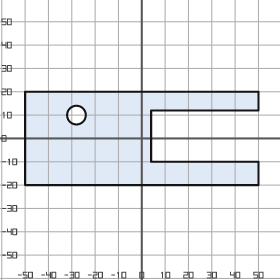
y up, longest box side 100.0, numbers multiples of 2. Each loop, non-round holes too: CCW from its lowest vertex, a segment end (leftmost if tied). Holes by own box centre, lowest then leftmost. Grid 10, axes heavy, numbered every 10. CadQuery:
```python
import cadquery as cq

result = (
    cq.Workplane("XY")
    .moveTo(-50.0, -20.0)
    .lineTo(50.0, -20.0)
    .lineTo(50.0, -10.0)
    .lineTo(4.0, -10.0)
    .lineTo(4.0, 12.0)
    .lineTo(50.0, 12.0)
    .lineTo(50.0, 20.0)
    .lineTo(-50.0, 20.0)
    .close()
    .moveTo(-28.0, 10.0)
    .circle(4.0)
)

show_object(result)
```